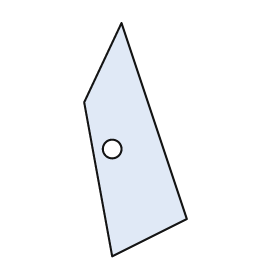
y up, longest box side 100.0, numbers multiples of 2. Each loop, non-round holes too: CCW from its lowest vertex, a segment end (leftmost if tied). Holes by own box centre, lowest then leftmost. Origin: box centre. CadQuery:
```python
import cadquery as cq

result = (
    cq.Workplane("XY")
    .moveTo(-10.0, -50.0)
    .lineTo(22.0, -34.0)
    .lineTo(-6.0, 50.0)
    .lineTo(-22.0, 16.0)
    .close()
    .moveTo(-10.0, -4.0)
    .circle(4.0)
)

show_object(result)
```